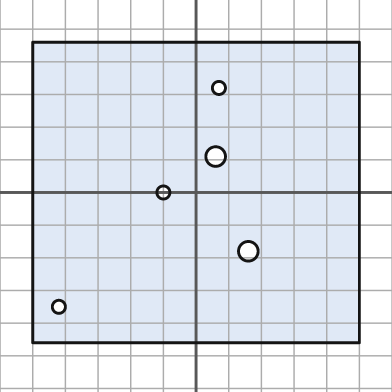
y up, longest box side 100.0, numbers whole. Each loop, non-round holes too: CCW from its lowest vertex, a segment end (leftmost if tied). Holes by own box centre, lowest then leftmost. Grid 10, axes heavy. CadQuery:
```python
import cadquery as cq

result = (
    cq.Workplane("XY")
    .moveTo(-50.0, -46.0)
    .lineTo(50.0, -46.0)
    .lineTo(50.0, 46.0)
    .lineTo(-50.0, 46.0)
    .close()
    .moveTo(-42.0, -35.0)
    .circle(2.0)
    .moveTo(16.0, -18.0)
    .circle(3.0)
    .moveTo(-10.0, 0.0)
    .circle(2.0)
    .moveTo(6.0, 11.0)
    .circle(3.0)
    .moveTo(7.0, 32.0)
    .circle(2.0)
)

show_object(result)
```